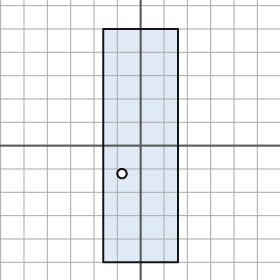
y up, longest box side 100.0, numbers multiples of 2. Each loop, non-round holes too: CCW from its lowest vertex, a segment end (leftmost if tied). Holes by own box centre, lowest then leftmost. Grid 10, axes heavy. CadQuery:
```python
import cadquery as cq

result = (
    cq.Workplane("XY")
    .moveTo(-16.0, -50.0)
    .lineTo(16.0, -50.0)
    .lineTo(16.0, 50.0)
    .lineTo(-16.0, 50.0)
    .close()
    .moveTo(-8.0, -12.0)
    .circle(2.0)
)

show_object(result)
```